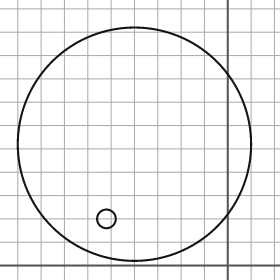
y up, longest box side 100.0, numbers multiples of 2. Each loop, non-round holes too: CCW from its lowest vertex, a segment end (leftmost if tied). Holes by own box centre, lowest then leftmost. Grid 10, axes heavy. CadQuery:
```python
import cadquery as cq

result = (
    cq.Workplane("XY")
    .moveTo(-40.0, 52.0)
    .circle(50.0)
    .moveTo(-52.0, 20.0)
    .circle(4.0)
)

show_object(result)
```